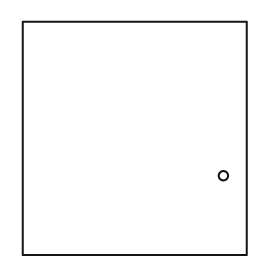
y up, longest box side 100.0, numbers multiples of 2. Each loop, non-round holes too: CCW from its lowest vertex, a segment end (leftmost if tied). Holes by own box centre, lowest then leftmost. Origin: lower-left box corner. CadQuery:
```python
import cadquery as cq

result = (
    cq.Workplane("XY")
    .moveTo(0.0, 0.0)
    .lineTo(96.0, 0.0)
    .lineTo(96.0, 100.0)
    .lineTo(0.0, 100.0)
    .close()
    .moveTo(86.0, 34.0)
    .circle(2.0)
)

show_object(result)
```